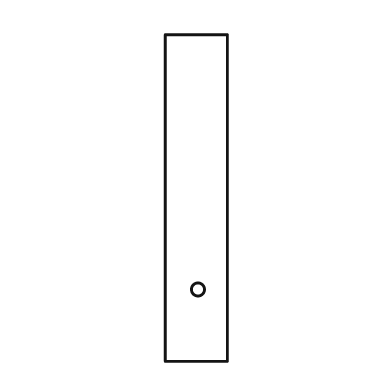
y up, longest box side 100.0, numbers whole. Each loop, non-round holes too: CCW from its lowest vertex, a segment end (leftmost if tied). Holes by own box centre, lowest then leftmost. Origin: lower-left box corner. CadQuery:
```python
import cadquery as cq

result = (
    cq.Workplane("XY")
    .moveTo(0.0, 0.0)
    .lineTo(19.0, 0.0)
    .lineTo(19.0, 100.0)
    .lineTo(0.0, 100.0)
    .close()
    .moveTo(10.0, 22.0)
    .circle(2.0)
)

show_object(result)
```